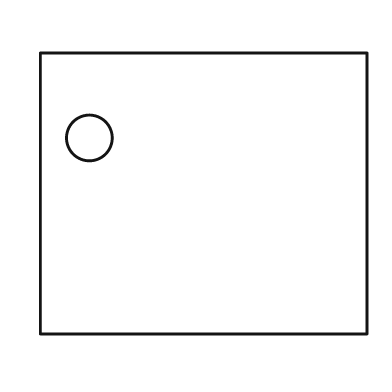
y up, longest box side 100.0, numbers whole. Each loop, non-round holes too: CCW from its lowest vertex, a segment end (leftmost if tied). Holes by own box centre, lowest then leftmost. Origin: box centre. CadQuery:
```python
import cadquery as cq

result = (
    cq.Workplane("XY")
    .moveTo(-50.0, -43.0)
    .lineTo(50.0, -43.0)
    .lineTo(50.0, 43.0)
    .lineTo(-50.0, 43.0)
    .close()
    .moveTo(-35.0, 17.0)
    .circle(7.0)
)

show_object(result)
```